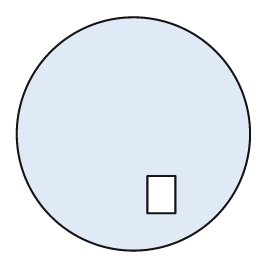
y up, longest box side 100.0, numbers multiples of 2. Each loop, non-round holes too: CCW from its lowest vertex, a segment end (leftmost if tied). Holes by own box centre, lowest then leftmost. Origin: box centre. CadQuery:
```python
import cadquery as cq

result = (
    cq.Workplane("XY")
    .moveTo(0.0, 0.0)
    .circle(50.0)
    .moveTo(6.0, -34.0)
    .lineTo(18.0, -34.0)
    .lineTo(18.0, -18.0)
    .lineTo(6.0, -18.0)
    .close()
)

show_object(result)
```